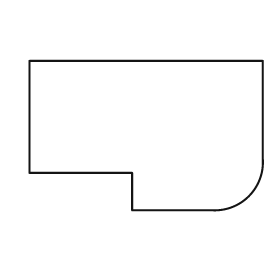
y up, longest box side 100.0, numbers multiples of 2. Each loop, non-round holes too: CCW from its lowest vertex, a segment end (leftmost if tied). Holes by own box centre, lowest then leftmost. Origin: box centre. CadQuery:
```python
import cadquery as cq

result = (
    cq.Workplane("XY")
    .moveTo(-6.0, -32.0)
    .lineTo(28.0, -32.0)
    .threePointArc((44.0, -26.0), (50.0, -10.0))
    .lineTo(50.0, 32.0)
    .lineTo(-50.0, 32.0)
    .lineTo(-50.0, -16.0)
    .lineTo(-6.0, -16.0)
    .close()
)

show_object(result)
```